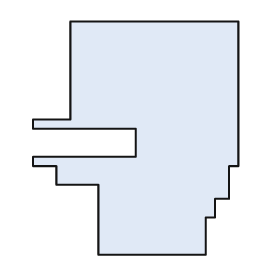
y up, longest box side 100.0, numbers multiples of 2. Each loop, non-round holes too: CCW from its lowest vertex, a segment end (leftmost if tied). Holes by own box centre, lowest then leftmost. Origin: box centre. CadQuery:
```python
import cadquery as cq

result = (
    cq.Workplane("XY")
    .moveTo(-16.0, -50.0)
    .lineTo(30.0, -50.0)
    .lineTo(30.0, -34.0)
    .lineTo(34.0, -34.0)
    .lineTo(34.0, -26.0)
    .lineTo(40.0, -26.0)
    .lineTo(40.0, -12.0)
    .lineTo(44.0, -12.0)
    .lineTo(44.0, 50.0)
    .lineTo(-28.0, 50.0)
    .lineTo(-28.0, 8.0)
    .lineTo(-44.0, 8.0)
    .lineTo(-44.0, 4.0)
    .lineTo(0.0, 4.0)
    .lineTo(0.0, -8.0)
    .lineTo(-44.0, -8.0)
    .lineTo(-44.0, -12.0)
    .lineTo(-34.0, -12.0)
    .lineTo(-34.0, -20.0)
    .lineTo(-16.0, -20.0)
    .close()
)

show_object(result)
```